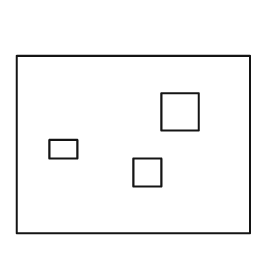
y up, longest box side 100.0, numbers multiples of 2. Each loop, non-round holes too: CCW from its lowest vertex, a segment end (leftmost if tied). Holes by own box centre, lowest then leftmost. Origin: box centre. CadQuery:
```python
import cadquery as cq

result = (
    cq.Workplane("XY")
    .moveTo(-50.0, -38.0)
    .lineTo(50.0, -38.0)
    .lineTo(50.0, 38.0)
    .lineTo(-50.0, 38.0)
    .close()
    .moveTo(0.0, -18.0)
    .lineTo(12.0, -18.0)
    .lineTo(12.0, -6.0)
    .lineTo(0.0, -6.0)
    .close()
    .moveTo(-36.0, -6.0)
    .lineTo(-24.0, -6.0)
    .lineTo(-24.0, 2.0)
    .lineTo(-36.0, 2.0)
    .close()
    .moveTo(12.0, 6.0)
    .lineTo(28.0, 6.0)
    .lineTo(28.0, 22.0)
    .lineTo(12.0, 22.0)
    .close()
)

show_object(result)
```